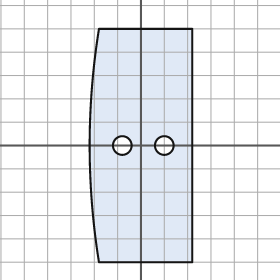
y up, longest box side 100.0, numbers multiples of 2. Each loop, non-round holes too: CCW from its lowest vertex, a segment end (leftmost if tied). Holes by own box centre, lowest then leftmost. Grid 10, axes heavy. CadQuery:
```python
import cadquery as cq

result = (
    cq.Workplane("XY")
    .moveTo(-18.0, -50.0)
    .lineTo(22.0, -50.0)
    .lineTo(22.0, 50.0)
    .lineTo(-18.0, 50.0)
    .threePointArc((-22.0, 0.0), (-18.0, -50.0))
    .close()
    .moveTo(-8.0, 0.0)
    .circle(4.0)
    .moveTo(10.0, 0.0)
    .circle(4.0)
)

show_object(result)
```